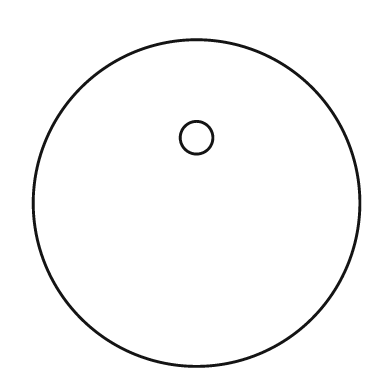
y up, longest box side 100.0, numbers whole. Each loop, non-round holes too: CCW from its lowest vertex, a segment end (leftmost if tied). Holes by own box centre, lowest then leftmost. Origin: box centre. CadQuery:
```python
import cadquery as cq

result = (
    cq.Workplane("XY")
    .moveTo(0.0, 0.0)
    .circle(50.0)
    .moveTo(0.0, 20.0)
    .circle(5.0)
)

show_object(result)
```